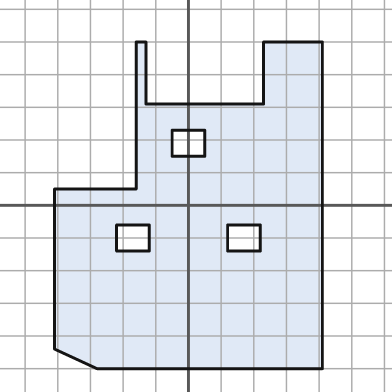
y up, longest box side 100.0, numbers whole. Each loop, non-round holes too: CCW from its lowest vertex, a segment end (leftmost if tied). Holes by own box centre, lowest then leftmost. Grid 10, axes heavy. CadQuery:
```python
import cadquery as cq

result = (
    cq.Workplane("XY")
    .moveTo(-28.0, -50.0)
    .lineTo(41.0, -50.0)
    .lineTo(41.0, 50.0)
    .lineTo(23.0, 50.0)
    .lineTo(23.0, 31.0)
    .lineTo(-13.0, 31.0)
    .lineTo(-13.0, 50.0)
    .lineTo(-16.0, 50.0)
    .lineTo(-16.0, 5.0)
    .lineTo(-41.0, 5.0)
    .lineTo(-41.0, -44.0)
    .close()
    .moveTo(-22.0, -14.0)
    .lineTo(-12.0, -14.0)
    .lineTo(-12.0, -6.0)
    .lineTo(-22.0, -6.0)
    .close()
    .moveTo(12.0, -14.0)
    .lineTo(22.0, -14.0)
    .lineTo(22.0, -6.0)
    .lineTo(12.0, -6.0)
    .close()
    .moveTo(-5.0, 15.0)
    .lineTo(5.0, 15.0)
    .lineTo(5.0, 23.0)
    .lineTo(-5.0, 23.0)
    .close()
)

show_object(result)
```